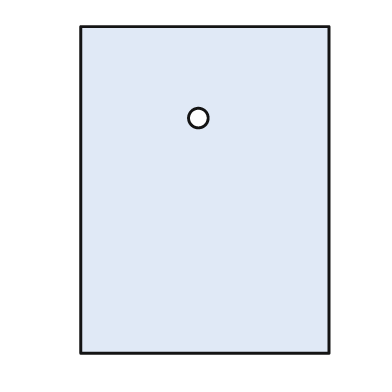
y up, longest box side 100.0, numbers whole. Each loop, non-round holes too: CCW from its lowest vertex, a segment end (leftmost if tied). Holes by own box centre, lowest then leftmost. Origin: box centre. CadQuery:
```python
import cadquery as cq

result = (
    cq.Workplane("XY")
    .moveTo(-38.0, -50.0)
    .lineTo(38.0, -50.0)
    .lineTo(38.0, 50.0)
    .lineTo(-38.0, 50.0)
    .close()
    .moveTo(-2.0, 22.0)
    .circle(3.0)
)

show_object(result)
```